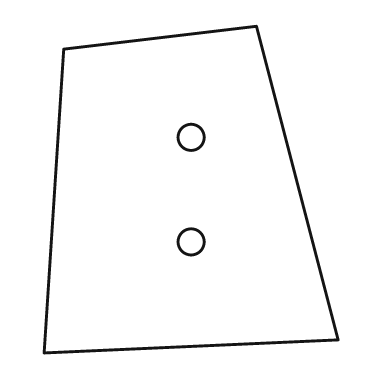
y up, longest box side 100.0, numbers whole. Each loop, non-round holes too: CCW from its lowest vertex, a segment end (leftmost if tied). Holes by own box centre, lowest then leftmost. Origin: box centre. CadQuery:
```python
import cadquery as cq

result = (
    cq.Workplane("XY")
    .moveTo(-45.0, -50.0)
    .lineTo(45.0, -46.0)
    .lineTo(20.0, 50.0)
    .lineTo(-39.0, 43.0)
    .close()
    .moveTo(0.0, -16.0)
    .circle(4.0)
    .moveTo(0.0, 16.0)
    .circle(4.0)
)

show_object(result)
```